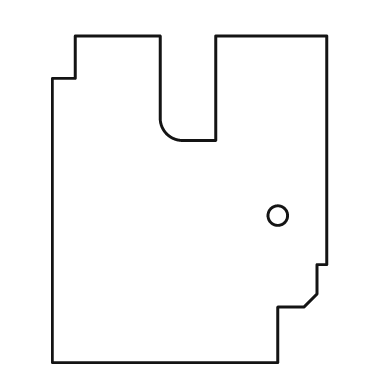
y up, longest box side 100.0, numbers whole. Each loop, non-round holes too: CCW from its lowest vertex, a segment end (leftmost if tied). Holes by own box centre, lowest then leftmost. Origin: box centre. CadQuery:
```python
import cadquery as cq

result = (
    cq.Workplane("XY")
    .moveTo(-42.0, -50.0)
    .lineTo(27.0, -50.0)
    .lineTo(27.0, -33.0)
    .lineTo(35.0, -33.0)
    .lineTo(39.0, -29.0)
    .lineTo(39.0, -20.0)
    .lineTo(42.0, -20.0)
    .lineTo(42.0, 50.0)
    .lineTo(8.0, 50.0)
    .lineTo(8.0, 18.0)
    .lineTo(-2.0, 18.0)
    .threePointArc((-7.0, 20.0), (-9.0, 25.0))
    .lineTo(-9.0, 50.0)
    .lineTo(-35.0, 50.0)
    .lineTo(-35.0, 37.0)
    .lineTo(-42.0, 37.0)
    .close()
    .moveTo(27.0, -5.0)
    .circle(3.0)
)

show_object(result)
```